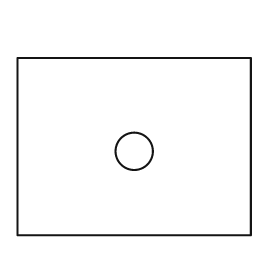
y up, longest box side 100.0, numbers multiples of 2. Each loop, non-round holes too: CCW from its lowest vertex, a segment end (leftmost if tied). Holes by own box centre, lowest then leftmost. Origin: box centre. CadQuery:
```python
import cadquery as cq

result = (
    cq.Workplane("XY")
    .moveTo(-50.0, -38.0)
    .lineTo(50.0, -38.0)
    .lineTo(50.0, 38.0)
    .lineTo(-50.0, 38.0)
    .close()
    .moveTo(0.0, -2.0)
    .circle(8.0)
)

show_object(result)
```